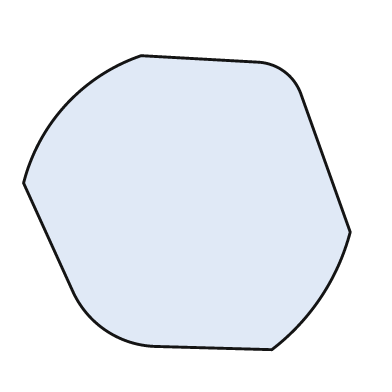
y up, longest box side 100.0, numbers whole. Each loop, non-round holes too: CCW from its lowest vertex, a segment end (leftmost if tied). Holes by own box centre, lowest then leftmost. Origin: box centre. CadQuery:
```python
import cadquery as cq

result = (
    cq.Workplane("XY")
    .moveTo(26.0, -45.0)
    .threePointArc((41.0, -29.0), (50.0, -9.0))
    .lineTo(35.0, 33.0)
    .threePointArc((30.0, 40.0), (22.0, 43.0))
    .lineTo(-14.0, 45.0)
    .threePointArc((-37.0, 30.0), (-50.0, 6.0))
    .lineTo(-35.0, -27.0)
    .threePointArc((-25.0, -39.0), (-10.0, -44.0))
    .close()
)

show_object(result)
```